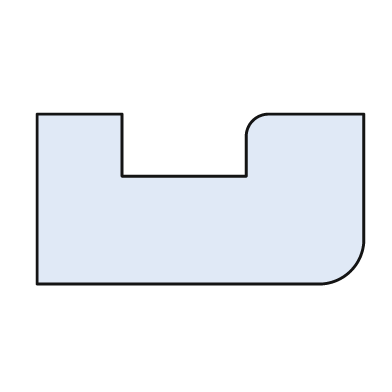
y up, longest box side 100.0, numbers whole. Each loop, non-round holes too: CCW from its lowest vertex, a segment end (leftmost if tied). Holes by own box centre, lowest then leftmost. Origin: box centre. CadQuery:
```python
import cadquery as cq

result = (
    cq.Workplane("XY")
    .moveTo(-50.0, -26.0)
    .lineTo(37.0, -26.0)
    .threePointArc((46.0, -22.0), (50.0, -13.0))
    .lineTo(50.0, 26.0)
    .lineTo(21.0, 26.0)
    .threePointArc((16.0, 24.0), (14.0, 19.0))
    .lineTo(14.0, 7.0)
    .lineTo(-24.0, 7.0)
    .lineTo(-24.0, 26.0)
    .lineTo(-50.0, 26.0)
    .close()
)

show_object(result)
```